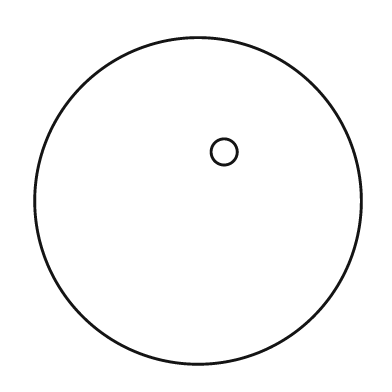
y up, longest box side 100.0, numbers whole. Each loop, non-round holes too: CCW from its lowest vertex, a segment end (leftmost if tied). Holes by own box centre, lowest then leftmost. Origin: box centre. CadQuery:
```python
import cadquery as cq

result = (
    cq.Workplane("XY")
    .moveTo(0.0, 0.0)
    .circle(50.0)
    .moveTo(8.0, 15.0)
    .circle(4.0)
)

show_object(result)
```